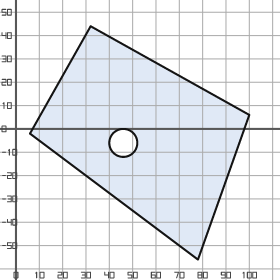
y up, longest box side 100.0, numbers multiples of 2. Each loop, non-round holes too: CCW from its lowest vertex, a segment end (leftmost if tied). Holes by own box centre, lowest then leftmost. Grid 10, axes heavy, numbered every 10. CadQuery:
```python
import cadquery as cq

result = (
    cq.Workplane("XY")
    .moveTo(78.0, -56.0)
    .lineTo(100.0, 6.0)
    .lineTo(32.0, 44.0)
    .lineTo(6.0, -2.0)
    .close()
    .moveTo(46.0, -6.0)
    .circle(6.0)
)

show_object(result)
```